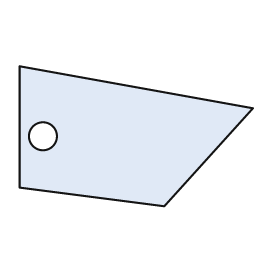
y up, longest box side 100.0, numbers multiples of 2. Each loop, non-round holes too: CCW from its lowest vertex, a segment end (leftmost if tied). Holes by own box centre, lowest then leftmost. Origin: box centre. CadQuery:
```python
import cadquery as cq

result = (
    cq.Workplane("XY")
    .moveTo(12.0, -30.0)
    .lineTo(50.0, 12.0)
    .lineTo(-50.0, 30.0)
    .lineTo(-50.0, -22.0)
    .close()
    .moveTo(-40.0, 0.0)
    .circle(6.0)
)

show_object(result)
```